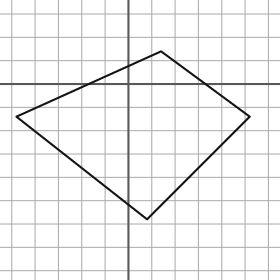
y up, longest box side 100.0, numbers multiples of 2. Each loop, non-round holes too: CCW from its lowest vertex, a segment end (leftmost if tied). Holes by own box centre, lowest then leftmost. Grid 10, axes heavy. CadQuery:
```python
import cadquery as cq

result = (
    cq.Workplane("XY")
    .moveTo(8.0, -58.0)
    .lineTo(52.0, -14.0)
    .lineTo(14.0, 14.0)
    .lineTo(-48.0, -14.0)
    .close()
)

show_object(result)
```